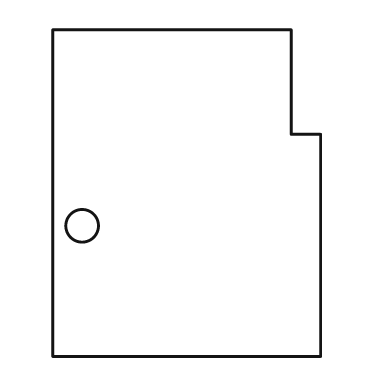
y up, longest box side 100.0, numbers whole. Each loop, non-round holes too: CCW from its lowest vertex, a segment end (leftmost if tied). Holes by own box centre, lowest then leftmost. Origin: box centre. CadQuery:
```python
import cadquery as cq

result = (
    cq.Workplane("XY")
    .moveTo(-41.0, -50.0)
    .lineTo(41.0, -50.0)
    .lineTo(41.0, 18.0)
    .lineTo(32.0, 18.0)
    .lineTo(32.0, 50.0)
    .lineTo(-41.0, 50.0)
    .close()
    .moveTo(-32.0, -10.0)
    .circle(5.0)
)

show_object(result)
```